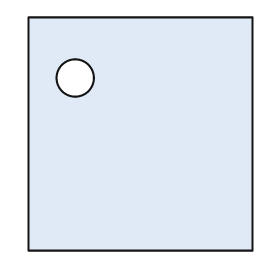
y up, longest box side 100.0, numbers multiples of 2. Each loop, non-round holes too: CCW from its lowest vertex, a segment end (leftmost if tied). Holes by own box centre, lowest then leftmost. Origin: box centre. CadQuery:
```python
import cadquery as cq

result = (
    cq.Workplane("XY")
    .moveTo(-48.0, -50.0)
    .lineTo(48.0, -50.0)
    .lineTo(48.0, 50.0)
    .lineTo(-48.0, 50.0)
    .close()
    .moveTo(-28.0, 24.0)
    .circle(8.0)
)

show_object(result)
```